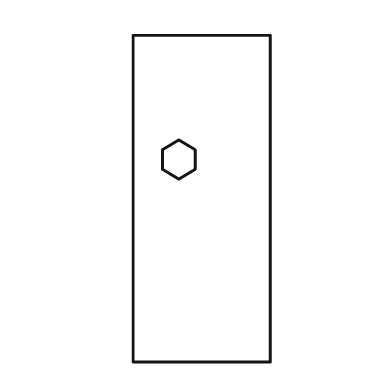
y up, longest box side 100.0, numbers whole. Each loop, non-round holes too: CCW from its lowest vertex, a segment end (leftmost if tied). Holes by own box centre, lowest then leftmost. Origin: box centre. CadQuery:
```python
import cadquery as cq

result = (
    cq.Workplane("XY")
    .moveTo(-21.0, -50.0)
    .lineTo(21.0, -50.0)
    .lineTo(21.0, 50.0)
    .lineTo(-21.0, 50.0)
    .close()
    .moveTo(-7.0, 6.0)
    .lineTo(-2.0, 9.0)
    .lineTo(-2.0, 15.0)
    .lineTo(-7.0, 18.0)
    .lineTo(-12.0, 15.0)
    .lineTo(-12.0, 9.0)
    .close()
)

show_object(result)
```